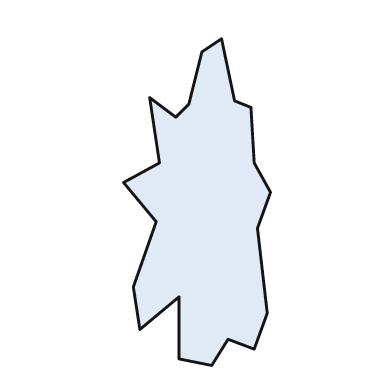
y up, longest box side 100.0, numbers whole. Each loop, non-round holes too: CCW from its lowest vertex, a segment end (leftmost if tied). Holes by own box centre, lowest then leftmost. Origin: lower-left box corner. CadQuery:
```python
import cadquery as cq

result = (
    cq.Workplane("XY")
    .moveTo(27.0, 0.0)
    .lineTo(32.0, 8.0)
    .lineTo(40.0, 5.0)
    .lineTo(44.0, 16.0)
    .lineTo(41.0, 42.0)
    .lineTo(45.0, 53.0)
    .lineTo(40.0, 62.0)
    .lineTo(39.0, 79.0)
    .lineTo(34.0, 81.0)
    .lineTo(30.0, 100.0)
    .lineTo(24.0, 96.0)
    .lineTo(20.0, 80.0)
    .lineTo(16.0, 76.0)
    .lineTo(8.0, 82.0)
    .lineTo(11.0, 62.0)
    .lineTo(0.0, 56.0)
    .lineTo(10.0, 44.0)
    .lineTo(3.0, 24.0)
    .lineTo(5.0, 11.0)
    .lineTo(17.0, 21.0)
    .lineTo(17.0, 2.0)
    .close()
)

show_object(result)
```